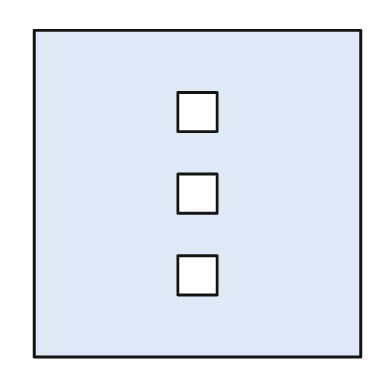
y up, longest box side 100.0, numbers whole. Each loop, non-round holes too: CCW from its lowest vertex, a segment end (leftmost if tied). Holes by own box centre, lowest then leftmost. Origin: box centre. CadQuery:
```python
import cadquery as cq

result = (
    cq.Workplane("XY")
    .moveTo(-50.0, -50.0)
    .lineTo(50.0, -50.0)
    .lineTo(50.0, 50.0)
    .lineTo(-50.0, 50.0)
    .close()
    .moveTo(-6.0, -31.0)
    .lineTo(6.0, -31.0)
    .lineTo(6.0, -19.0)
    .lineTo(-6.0, -19.0)
    .close()
    .moveTo(-6.0, -6.0)
    .lineTo(6.0, -6.0)
    .lineTo(6.0, 6.0)
    .lineTo(-6.0, 6.0)
    .close()
    .moveTo(-6.0, 19.0)
    .lineTo(6.0, 19.0)
    .lineTo(6.0, 31.0)
    .lineTo(-6.0, 31.0)
    .close()
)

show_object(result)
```